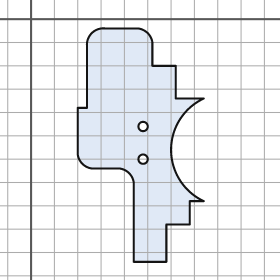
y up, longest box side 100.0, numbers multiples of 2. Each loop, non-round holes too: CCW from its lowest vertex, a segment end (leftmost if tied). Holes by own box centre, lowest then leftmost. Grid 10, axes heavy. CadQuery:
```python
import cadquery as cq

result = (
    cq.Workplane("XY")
    .moveTo(44.0, -104.0)
    .lineTo(58.0, -104.0)
    .lineTo(58.0, -88.0)
    .lineTo(68.0, -88.0)
    .lineTo(68.0, -78.0)
    .lineTo(74.0, -78.0)
    .threePointArc((60.0, -56.0), (74.0, -34.0))
    .lineTo(62.0, -34.0)
    .lineTo(62.0, -20.0)
    .lineTo(52.0, -20.0)
    .lineTo(52.0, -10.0)
    .threePointArc((50.0, -6.0), (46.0, -4.0))
    .lineTo(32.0, -4.0)
    .threePointArc((26.0, -6.0), (24.0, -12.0))
    .lineTo(24.0, -38.0)
    .lineTo(20.0, -38.0)
    .lineTo(20.0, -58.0)
    .threePointArc((22.0, -62.0), (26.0, -64.0))
    .lineTo(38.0, -64.0)
    .threePointArc((42.0, -66.0), (44.0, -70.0))
    .close()
    .moveTo(48.0, -60.0)
    .circle(2.0)
    .moveTo(48.0, -46.0)
    .circle(2.0)
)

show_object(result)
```